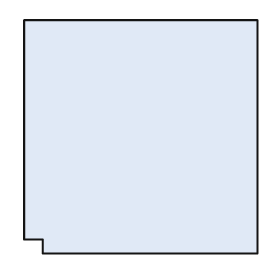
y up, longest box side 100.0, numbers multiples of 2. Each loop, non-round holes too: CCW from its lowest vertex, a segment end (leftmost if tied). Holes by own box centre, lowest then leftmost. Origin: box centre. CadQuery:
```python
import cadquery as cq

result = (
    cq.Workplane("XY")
    .moveTo(-42.0, -50.0)
    .lineTo(50.0, -50.0)
    .lineTo(50.0, 50.0)
    .lineTo(-50.0, 50.0)
    .lineTo(-50.0, -44.0)
    .lineTo(-42.0, -44.0)
    .close()
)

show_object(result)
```